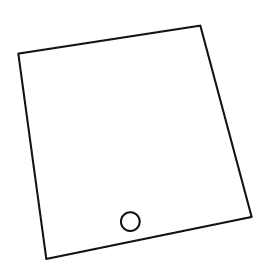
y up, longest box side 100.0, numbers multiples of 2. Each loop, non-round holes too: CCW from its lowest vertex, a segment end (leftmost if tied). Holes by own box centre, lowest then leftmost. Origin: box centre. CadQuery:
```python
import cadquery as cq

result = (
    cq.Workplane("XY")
    .moveTo(-38.0, -50.0)
    .lineTo(50.0, -32.0)
    .lineTo(28.0, 50.0)
    .lineTo(-50.0, 38.0)
    .close()
    .moveTo(-2.0, -34.0)
    .circle(4.0)
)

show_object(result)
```